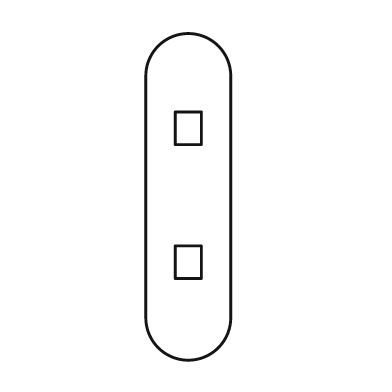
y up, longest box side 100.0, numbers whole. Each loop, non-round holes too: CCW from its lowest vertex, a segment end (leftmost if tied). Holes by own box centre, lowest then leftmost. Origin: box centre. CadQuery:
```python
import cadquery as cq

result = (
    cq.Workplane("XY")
    .moveTo(-13.0, -37.0)
    .threePointArc((0.0, -50.0), (13.0, -37.0))
    .lineTo(13.0, 37.0)
    .threePointArc((0.0, 50.0), (-13.0, 37.0))
    .close()
    .moveTo(-4.0, -25.0)
    .lineTo(4.0, -25.0)
    .lineTo(4.0, -15.0)
    .lineTo(-4.0, -15.0)
    .close()
    .moveTo(-4.0, 16.0)
    .lineTo(4.0, 16.0)
    .lineTo(4.0, 26.0)
    .lineTo(-4.0, 26.0)
    .close()
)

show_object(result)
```